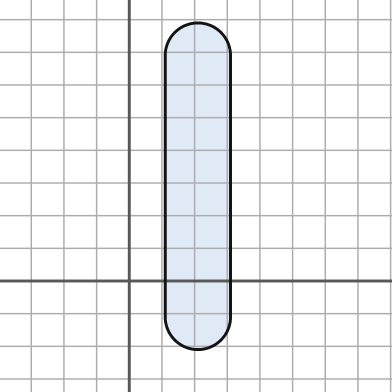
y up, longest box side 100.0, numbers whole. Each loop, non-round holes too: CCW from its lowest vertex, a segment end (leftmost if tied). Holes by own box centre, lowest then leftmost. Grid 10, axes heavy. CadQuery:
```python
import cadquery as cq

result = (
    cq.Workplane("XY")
    .moveTo(11.0, -11.0)
    .threePointArc((21.0, -21.0), (31.0, -11.0))
    .lineTo(31.0, 69.0)
    .threePointArc((21.0, 79.0), (11.0, 69.0))
    .close()
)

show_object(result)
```